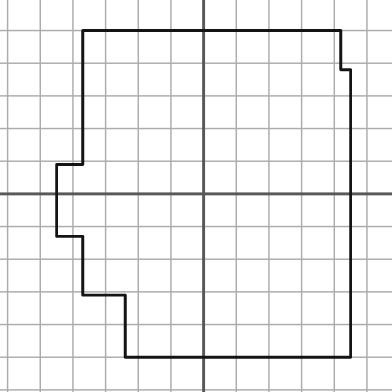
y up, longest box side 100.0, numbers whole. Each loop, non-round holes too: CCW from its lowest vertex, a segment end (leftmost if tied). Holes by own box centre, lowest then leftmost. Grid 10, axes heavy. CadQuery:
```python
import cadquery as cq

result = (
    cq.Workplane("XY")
    .moveTo(-24.0, -50.0)
    .lineTo(45.0, -50.0)
    .lineTo(45.0, 38.0)
    .lineTo(42.0, 38.0)
    .lineTo(42.0, 50.0)
    .lineTo(-37.0, 50.0)
    .lineTo(-37.0, 9.0)
    .lineTo(-45.0, 9.0)
    .lineTo(-45.0, -13.0)
    .lineTo(-37.0, -13.0)
    .lineTo(-37.0, -31.0)
    .lineTo(-24.0, -31.0)
    .close()
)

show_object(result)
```